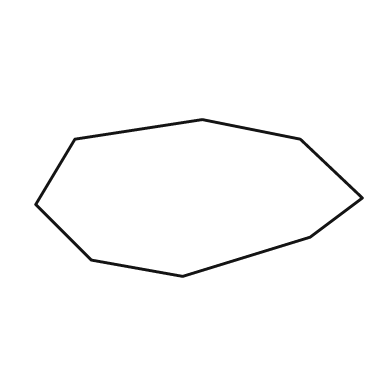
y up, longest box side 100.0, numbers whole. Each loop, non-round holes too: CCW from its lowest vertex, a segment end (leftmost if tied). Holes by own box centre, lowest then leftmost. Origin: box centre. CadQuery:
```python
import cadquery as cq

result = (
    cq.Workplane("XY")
    .moveTo(-5.0, -24.0)
    .lineTo(34.0, -12.0)
    .lineTo(50.0, 0.0)
    .lineTo(31.0, 18.0)
    .lineTo(1.0, 24.0)
    .lineTo(-38.0, 18.0)
    .lineTo(-50.0, -2.0)
    .lineTo(-33.0, -19.0)
    .close()
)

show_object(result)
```